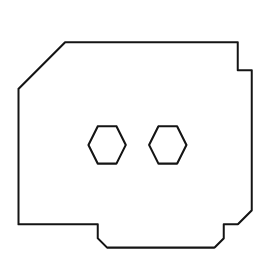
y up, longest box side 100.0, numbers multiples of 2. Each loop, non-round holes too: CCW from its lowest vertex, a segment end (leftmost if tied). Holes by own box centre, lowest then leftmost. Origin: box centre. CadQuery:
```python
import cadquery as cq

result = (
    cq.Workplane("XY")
    .moveTo(-12.0, -44.0)
    .lineTo(34.0, -44.0)
    .lineTo(38.0, -40.0)
    .lineTo(38.0, -34.0)
    .lineTo(44.0, -34.0)
    .lineTo(50.0, -28.0)
    .lineTo(50.0, 32.0)
    .lineTo(44.0, 32.0)
    .lineTo(44.0, 44.0)
    .lineTo(-30.0, 44.0)
    .lineTo(-50.0, 24.0)
    .lineTo(-50.0, -34.0)
    .lineTo(-16.0, -34.0)
    .lineTo(-16.0, -40.0)
    .close()
    .moveTo(-16.0, -8.0)
    .lineTo(-8.0, -8.0)
    .lineTo(-4.0, 0.0)
    .lineTo(-8.0, 8.0)
    .lineTo(-16.0, 8.0)
    .lineTo(-20.0, 0.0)
    .close()
    .moveTo(10.0, -8.0)
    .lineTo(18.0, -8.0)
    .lineTo(22.0, 0.0)
    .lineTo(18.0, 8.0)
    .lineTo(10.0, 8.0)
    .lineTo(6.0, 0.0)
    .close()
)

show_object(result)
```